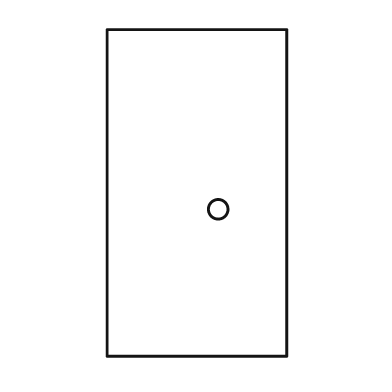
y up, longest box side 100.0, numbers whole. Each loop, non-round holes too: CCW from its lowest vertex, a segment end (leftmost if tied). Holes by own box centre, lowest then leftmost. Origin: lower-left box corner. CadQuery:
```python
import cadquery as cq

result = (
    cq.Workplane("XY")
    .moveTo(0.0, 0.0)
    .lineTo(55.0, 0.0)
    .lineTo(55.0, 100.0)
    .lineTo(0.0, 100.0)
    .close()
    .moveTo(34.0, 45.0)
    .circle(3.0)
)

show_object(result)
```